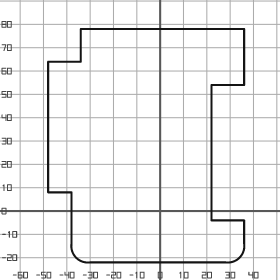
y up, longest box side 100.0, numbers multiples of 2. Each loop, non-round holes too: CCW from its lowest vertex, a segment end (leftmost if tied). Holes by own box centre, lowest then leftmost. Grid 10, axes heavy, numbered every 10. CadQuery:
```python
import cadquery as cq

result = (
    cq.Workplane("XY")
    .moveTo(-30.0, -22.0)
    .lineTo(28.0, -22.0)
    .threePointArc((34.0, -20.0), (36.0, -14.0))
    .lineTo(36.0, -4.0)
    .lineTo(22.0, -4.0)
    .lineTo(22.0, 54.0)
    .lineTo(36.0, 54.0)
    .lineTo(36.0, 78.0)
    .lineTo(-34.0, 78.0)
    .lineTo(-34.0, 64.0)
    .lineTo(-48.0, 64.0)
    .lineTo(-48.0, 8.0)
    .lineTo(-38.0, 8.0)
    .lineTo(-38.0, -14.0)
    .threePointArc((-36.0, -20.0), (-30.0, -22.0))
    .close()
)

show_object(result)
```